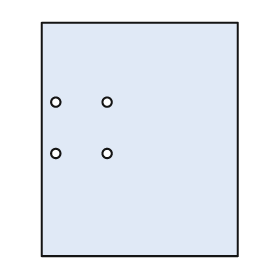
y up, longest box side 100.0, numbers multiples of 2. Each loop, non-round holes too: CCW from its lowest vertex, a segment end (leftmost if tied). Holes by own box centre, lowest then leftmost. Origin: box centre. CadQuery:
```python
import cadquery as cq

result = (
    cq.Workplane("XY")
    .moveTo(-42.0, -50.0)
    .lineTo(42.0, -50.0)
    .lineTo(42.0, 50.0)
    .lineTo(-42.0, 50.0)
    .close()
    .moveTo(-36.0, -6.0)
    .circle(2.0)
    .moveTo(-14.0, -6.0)
    .circle(2.0)
    .moveTo(-36.0, 16.0)
    .circle(2.0)
    .moveTo(-14.0, 16.0)
    .circle(2.0)
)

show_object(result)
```